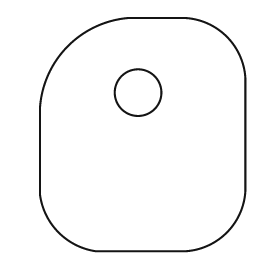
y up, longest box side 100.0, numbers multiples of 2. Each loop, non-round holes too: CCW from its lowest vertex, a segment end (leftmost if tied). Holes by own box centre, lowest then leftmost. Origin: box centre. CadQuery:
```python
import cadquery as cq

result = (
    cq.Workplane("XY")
    .moveTo(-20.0, -50.0)
    .lineTo(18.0, -50.0)
    .threePointArc((36.0, -42.0), (44.0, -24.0))
    .lineTo(44.0, 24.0)
    .threePointArc((36.0, 42.0), (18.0, 50.0))
    .lineTo(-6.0, 50.0)
    .threePointArc((-32.0, 38.0), (-44.0, 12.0))
    .lineTo(-44.0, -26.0)
    .threePointArc((-36.0, -42.0), (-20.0, -50.0))
    .close()
    .moveTo(-2.0, 18.0)
    .circle(10.0)
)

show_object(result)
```